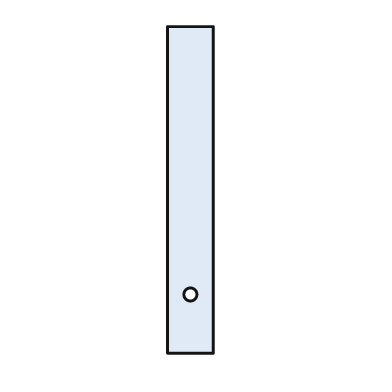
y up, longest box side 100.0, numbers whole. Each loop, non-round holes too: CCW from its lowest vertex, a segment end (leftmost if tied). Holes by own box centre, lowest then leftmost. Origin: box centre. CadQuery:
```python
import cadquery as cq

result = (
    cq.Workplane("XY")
    .moveTo(-7.0, -50.0)
    .lineTo(7.0, -50.0)
    .lineTo(7.0, 50.0)
    .lineTo(-7.0, 50.0)
    .close()
    .moveTo(0.0, -32.0)
    .circle(2.0)
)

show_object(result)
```